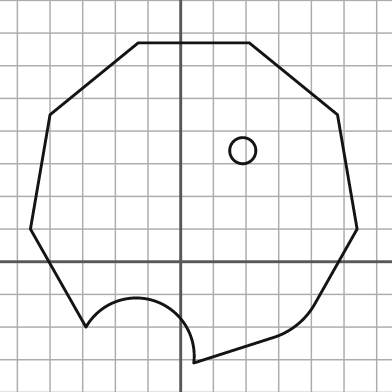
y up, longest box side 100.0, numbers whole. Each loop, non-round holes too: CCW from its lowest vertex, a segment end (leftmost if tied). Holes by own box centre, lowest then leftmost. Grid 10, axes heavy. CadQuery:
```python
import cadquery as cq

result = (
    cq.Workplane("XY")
    .moveTo(4.0, -31.0)
    .lineTo(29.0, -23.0)
    .threePointArc((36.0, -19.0), (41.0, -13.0))
    .lineTo(54.0, 10.0)
    .lineTo(48.0, 45.0)
    .lineTo(21.0, 67.0)
    .lineTo(-13.0, 67.0)
    .lineTo(-40.0, 45.0)
    .lineTo(-46.0, 10.0)
    .lineTo(-29.0, -20.0)
    .threePointArc((-8.0, -12.0), (4.0, -31.0))
    .close()
    .moveTo(19.0, 34.0)
    .circle(4.0)
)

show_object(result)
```